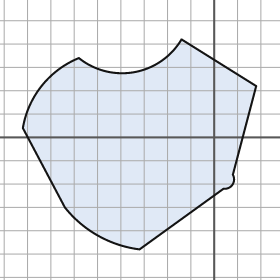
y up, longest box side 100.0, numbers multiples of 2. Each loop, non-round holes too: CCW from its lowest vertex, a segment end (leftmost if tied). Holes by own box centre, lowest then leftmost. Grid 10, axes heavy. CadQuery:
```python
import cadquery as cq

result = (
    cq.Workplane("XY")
    .moveTo(-32.0, -48.0)
    .lineTo(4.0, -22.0)
    .threePointArc((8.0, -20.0), (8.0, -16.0))
    .lineTo(18.0, 22.0)
    .lineTo(-14.0, 42.0)
    .threePointArc((-34.0, 28.0), (-58.0, 34.0))
    .threePointArc((-74.0, 22.0), (-82.0, 4.0))
    .lineTo(-64.0, -30.0)
    .threePointArc((-50.0, -42.0), (-32.0, -48.0))
    .close()
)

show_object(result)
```